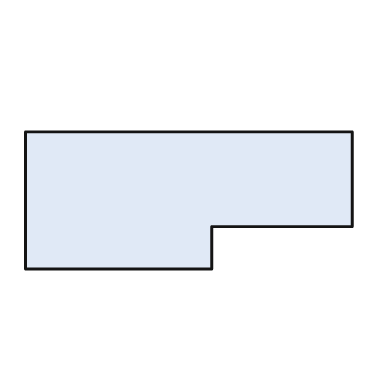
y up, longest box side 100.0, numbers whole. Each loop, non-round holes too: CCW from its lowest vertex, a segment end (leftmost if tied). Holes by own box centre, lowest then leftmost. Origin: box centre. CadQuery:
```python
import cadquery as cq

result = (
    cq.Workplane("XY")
    .moveTo(-50.0, -21.0)
    .lineTo(7.0, -21.0)
    .lineTo(7.0, -8.0)
    .lineTo(50.0, -8.0)
    .lineTo(50.0, 21.0)
    .lineTo(-50.0, 21.0)
    .close()
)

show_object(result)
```